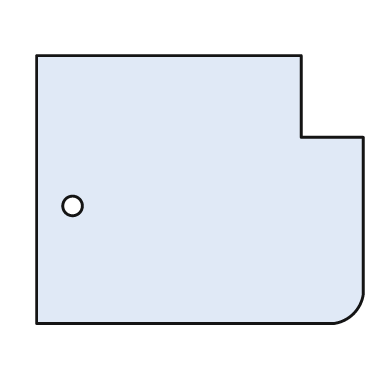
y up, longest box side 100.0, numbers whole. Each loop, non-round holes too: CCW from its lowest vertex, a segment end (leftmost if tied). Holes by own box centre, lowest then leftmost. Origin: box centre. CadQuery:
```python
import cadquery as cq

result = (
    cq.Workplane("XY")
    .moveTo(-50.0, -41.0)
    .lineTo(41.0, -41.0)
    .threePointArc((47.0, -38.0), (50.0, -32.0))
    .lineTo(50.0, 16.0)
    .lineTo(31.0, 16.0)
    .lineTo(31.0, 41.0)
    .lineTo(-50.0, 41.0)
    .close()
    .moveTo(-39.0, -5.0)
    .circle(3.0)
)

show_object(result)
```